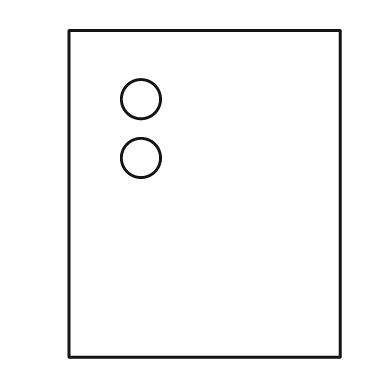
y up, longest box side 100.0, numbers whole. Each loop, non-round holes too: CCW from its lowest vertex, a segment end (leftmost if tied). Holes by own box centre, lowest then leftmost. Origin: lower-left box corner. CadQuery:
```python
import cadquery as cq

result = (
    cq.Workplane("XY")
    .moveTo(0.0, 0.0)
    .lineTo(83.0, 0.0)
    .lineTo(83.0, 100.0)
    .lineTo(0.0, 100.0)
    .close()
    .moveTo(22.0, 61.0)
    .circle(6.0)
    .moveTo(22.0, 79.0)
    .circle(6.0)
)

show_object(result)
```